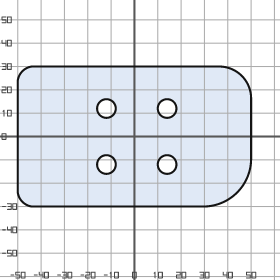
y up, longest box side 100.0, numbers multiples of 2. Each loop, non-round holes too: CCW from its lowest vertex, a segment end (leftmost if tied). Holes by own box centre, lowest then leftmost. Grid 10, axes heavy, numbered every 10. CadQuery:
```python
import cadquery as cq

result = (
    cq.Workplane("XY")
    .moveTo(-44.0, -30.0)
    .lineTo(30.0, -30.0)
    .threePointArc((44.0, -24.0), (50.0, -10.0))
    .lineTo(50.0, 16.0)
    .threePointArc((46.0, 26.0), (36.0, 30.0))
    .lineTo(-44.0, 30.0)
    .threePointArc((-48.0, 28.0), (-50.0, 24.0))
    .lineTo(-50.0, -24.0)
    .threePointArc((-48.0, -28.0), (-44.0, -30.0))
    .close()
    .moveTo(-12.0, -12.0)
    .circle(4.0)
    .moveTo(14.0, -12.0)
    .circle(4.0)
    .moveTo(-12.0, 12.0)
    .circle(4.0)
    .moveTo(14.0, 12.0)
    .circle(4.0)
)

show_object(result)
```